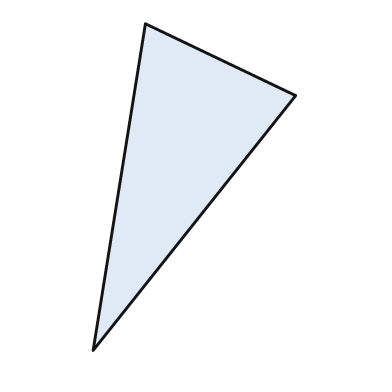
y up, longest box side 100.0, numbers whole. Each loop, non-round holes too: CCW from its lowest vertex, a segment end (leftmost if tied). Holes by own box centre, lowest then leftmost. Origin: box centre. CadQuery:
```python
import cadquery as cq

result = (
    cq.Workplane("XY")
    .moveTo(-31.0, -50.0)
    .lineTo(31.0, 28.0)
    .lineTo(-15.0, 50.0)
    .close()
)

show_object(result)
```